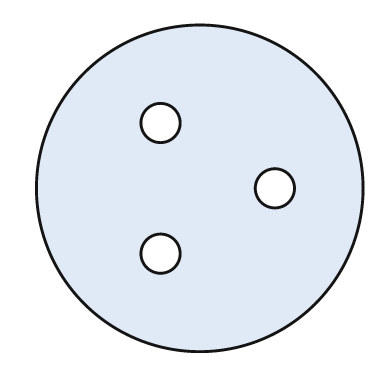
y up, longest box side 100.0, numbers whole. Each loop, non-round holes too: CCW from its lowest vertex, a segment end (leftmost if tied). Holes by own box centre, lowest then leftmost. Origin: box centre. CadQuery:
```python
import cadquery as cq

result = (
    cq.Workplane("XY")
    .moveTo(0.0, 0.0)
    .circle(50.0)
    .moveTo(-12.0, -20.0)
    .circle(6.0)
    .moveTo(23.0, 0.0)
    .circle(6.0)
    .moveTo(-12.0, 20.0)
    .circle(6.0)
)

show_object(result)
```